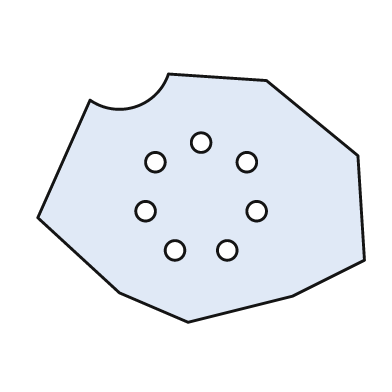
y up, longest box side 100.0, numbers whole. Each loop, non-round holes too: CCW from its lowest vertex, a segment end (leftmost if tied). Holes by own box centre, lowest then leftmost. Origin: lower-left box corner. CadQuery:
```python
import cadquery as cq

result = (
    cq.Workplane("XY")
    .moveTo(46.0, 0.0)
    .lineTo(78.0, 8.0)
    .lineTo(100.0, 19.0)
    .lineTo(98.0, 51.0)
    .lineTo(70.0, 74.0)
    .lineTo(40.0, 76.0)
    .threePointArc((30.0, 66.0), (16.0, 68.0))
    .lineTo(0.0, 32.0)
    .lineTo(25.0, 9.0)
    .close()
    .moveTo(42.0, 22.0)
    .circle(3.0)
    .moveTo(58.0, 22.0)
    .circle(3.0)
    .moveTo(33.0, 34.0)
    .circle(3.0)
    .moveTo(67.0, 34.0)
    .circle(3.0)
    .moveTo(36.0, 49.0)
    .circle(3.0)
    .moveTo(64.0, 49.0)
    .circle(3.0)
    .moveTo(50.0, 55.0)
    .circle(3.0)
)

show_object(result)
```